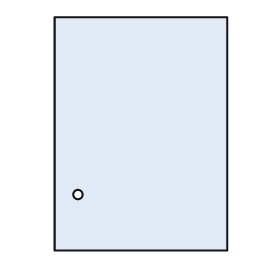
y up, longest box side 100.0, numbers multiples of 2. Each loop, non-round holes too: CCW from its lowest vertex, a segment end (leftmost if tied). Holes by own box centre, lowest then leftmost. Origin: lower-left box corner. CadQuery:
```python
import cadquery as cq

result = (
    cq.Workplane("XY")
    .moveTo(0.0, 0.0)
    .lineTo(74.0, 0.0)
    .lineTo(74.0, 100.0)
    .lineTo(0.0, 100.0)
    .close()
    .moveTo(10.0, 24.0)
    .circle(2.0)
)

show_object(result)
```